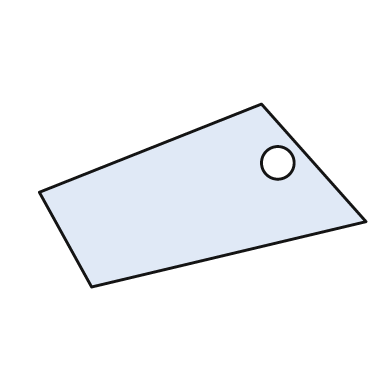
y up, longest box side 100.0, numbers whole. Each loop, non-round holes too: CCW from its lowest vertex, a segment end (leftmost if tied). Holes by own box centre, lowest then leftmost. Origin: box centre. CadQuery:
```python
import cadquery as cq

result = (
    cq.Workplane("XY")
    .moveTo(-34.0, -28.0)
    .lineTo(50.0, -8.0)
    .lineTo(18.0, 28.0)
    .lineTo(-50.0, 1.0)
    .close()
    .moveTo(23.0, 10.0)
    .circle(5.0)
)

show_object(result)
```